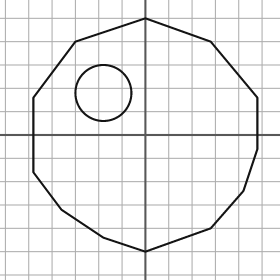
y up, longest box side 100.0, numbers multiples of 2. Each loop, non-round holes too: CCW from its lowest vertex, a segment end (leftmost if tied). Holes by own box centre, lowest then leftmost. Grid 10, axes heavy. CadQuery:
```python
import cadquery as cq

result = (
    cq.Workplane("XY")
    .moveTo(0.0, -50.0)
    .lineTo(28.0, -40.0)
    .lineTo(42.0, -24.0)
    .lineTo(48.0, -6.0)
    .lineTo(48.0, 16.0)
    .lineTo(28.0, 40.0)
    .lineTo(0.0, 50.0)
    .lineTo(-30.0, 40.0)
    .lineTo(-48.0, 16.0)
    .lineTo(-48.0, -16.0)
    .lineTo(-36.0, -32.0)
    .lineTo(-18.0, -44.0)
    .close()
    .moveTo(-18.0, 18.0)
    .circle(12.0)
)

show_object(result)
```